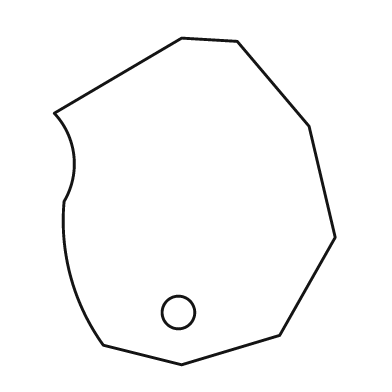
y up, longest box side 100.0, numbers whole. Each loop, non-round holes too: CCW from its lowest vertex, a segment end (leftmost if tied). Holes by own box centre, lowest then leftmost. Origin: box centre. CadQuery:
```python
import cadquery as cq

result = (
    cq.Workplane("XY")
    .moveTo(-4.0, -50.0)
    .lineTo(26.0, -41.0)
    .lineTo(43.0, -11.0)
    .lineTo(35.0, 23.0)
    .lineTo(13.0, 49.0)
    .lineTo(-4.0, 50.0)
    .lineTo(-43.0, 27.0)
    .threePointArc((-37.0, 14.0), (-40.0, 0.0))
    .threePointArc((-38.0, -23.0), (-28.0, -44.0))
    .close()
    .moveTo(-5.0, -34.0)
    .circle(5.0)
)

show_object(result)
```